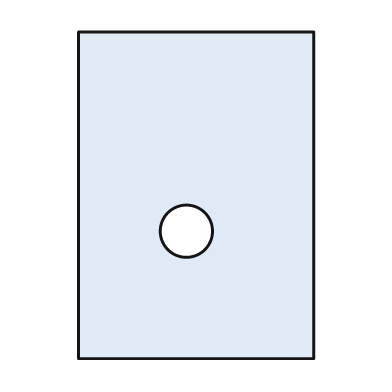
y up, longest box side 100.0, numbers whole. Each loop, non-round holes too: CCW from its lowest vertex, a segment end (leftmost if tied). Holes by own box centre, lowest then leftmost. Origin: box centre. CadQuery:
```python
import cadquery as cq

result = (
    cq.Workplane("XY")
    .moveTo(-36.0, -50.0)
    .lineTo(36.0, -50.0)
    .lineTo(36.0, 50.0)
    .lineTo(-36.0, 50.0)
    .close()
    .moveTo(-3.0, -11.0)
    .circle(8.0)
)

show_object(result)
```